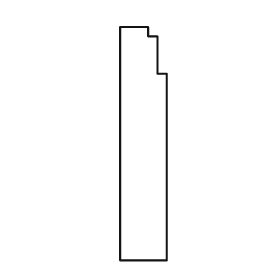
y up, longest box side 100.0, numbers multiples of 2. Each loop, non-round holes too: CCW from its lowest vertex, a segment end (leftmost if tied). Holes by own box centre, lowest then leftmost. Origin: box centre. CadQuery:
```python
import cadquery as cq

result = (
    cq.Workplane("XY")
    .moveTo(-10.0, -50.0)
    .lineTo(10.0, -50.0)
    .lineTo(10.0, 30.0)
    .lineTo(6.0, 30.0)
    .lineTo(6.0, 46.0)
    .lineTo(2.0, 46.0)
    .lineTo(2.0, 50.0)
    .lineTo(-10.0, 50.0)
    .close()
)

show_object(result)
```